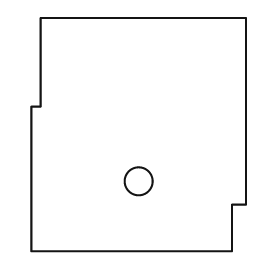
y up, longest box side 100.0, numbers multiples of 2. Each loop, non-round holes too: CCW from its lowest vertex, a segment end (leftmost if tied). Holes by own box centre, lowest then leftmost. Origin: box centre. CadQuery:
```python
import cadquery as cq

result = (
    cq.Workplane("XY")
    .moveTo(-46.0, -50.0)
    .lineTo(40.0, -50.0)
    .lineTo(40.0, -30.0)
    .lineTo(46.0, -30.0)
    .lineTo(46.0, 50.0)
    .lineTo(-42.0, 50.0)
    .lineTo(-42.0, 12.0)
    .lineTo(-46.0, 12.0)
    .close()
    .moveTo(0.0, -20.0)
    .circle(6.0)
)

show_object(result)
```